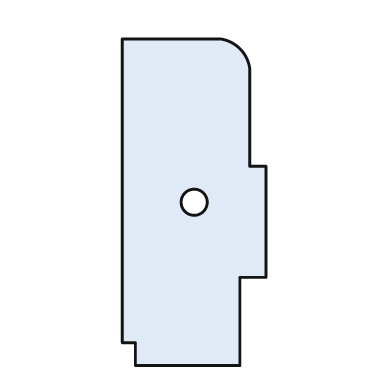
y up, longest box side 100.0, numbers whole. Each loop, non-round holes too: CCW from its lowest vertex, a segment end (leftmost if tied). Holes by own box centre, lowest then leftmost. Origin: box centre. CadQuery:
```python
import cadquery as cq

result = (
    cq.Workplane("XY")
    .moveTo(-18.0, -50.0)
    .lineTo(14.0, -50.0)
    .lineTo(14.0, -23.0)
    .lineTo(22.0, -23.0)
    .lineTo(22.0, 11.0)
    .lineTo(17.0, 11.0)
    .lineTo(17.0, 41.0)
    .threePointArc((14.0, 47.0), (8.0, 50.0))
    .lineTo(-22.0, 50.0)
    .lineTo(-22.0, -43.0)
    .lineTo(-18.0, -43.0)
    .close()
    .moveTo(0.0, 0.0)
    .circle(4.0)
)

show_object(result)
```